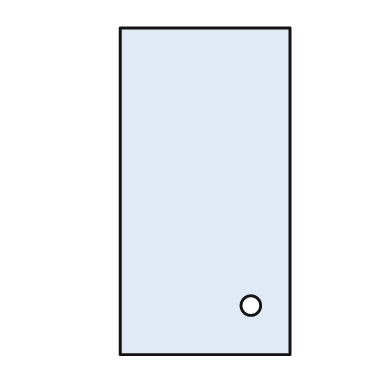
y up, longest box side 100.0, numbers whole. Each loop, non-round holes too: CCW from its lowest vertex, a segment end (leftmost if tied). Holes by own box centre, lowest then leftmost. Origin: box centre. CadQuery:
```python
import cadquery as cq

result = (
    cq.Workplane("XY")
    .moveTo(-26.0, -50.0)
    .lineTo(26.0, -50.0)
    .lineTo(26.0, 50.0)
    .lineTo(-26.0, 50.0)
    .close()
    .moveTo(14.0, -35.0)
    .circle(3.0)
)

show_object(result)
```